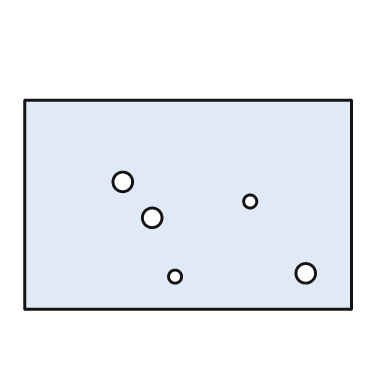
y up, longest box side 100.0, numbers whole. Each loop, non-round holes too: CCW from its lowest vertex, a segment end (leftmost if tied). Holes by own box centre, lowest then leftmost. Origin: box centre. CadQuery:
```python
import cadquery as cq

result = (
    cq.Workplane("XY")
    .moveTo(-50.0, -32.0)
    .lineTo(50.0, -32.0)
    .lineTo(50.0, 32.0)
    .lineTo(-50.0, 32.0)
    .close()
    .moveTo(-4.0, -22.0)
    .circle(2.0)
    .moveTo(36.0, -21.0)
    .circle(3.0)
    .moveTo(-11.0, -4.0)
    .circle(3.0)
    .moveTo(19.0, 1.0)
    .circle(2.0)
    .moveTo(-20.0, 7.0)
    .circle(3.0)
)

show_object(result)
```